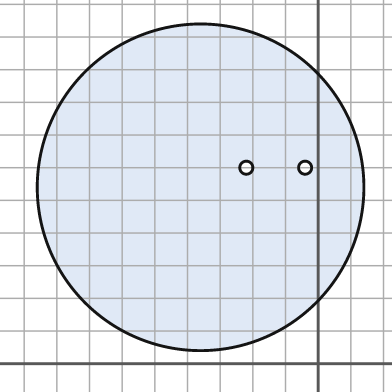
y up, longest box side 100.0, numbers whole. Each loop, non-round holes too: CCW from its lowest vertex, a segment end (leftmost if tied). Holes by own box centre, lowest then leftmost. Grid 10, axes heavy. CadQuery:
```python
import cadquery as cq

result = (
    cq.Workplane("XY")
    .moveTo(-36.0, 54.0)
    .circle(50.0)
    .moveTo(-22.0, 60.0)
    .circle(2.0)
    .moveTo(-4.0, 60.0)
    .circle(2.0)
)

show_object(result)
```